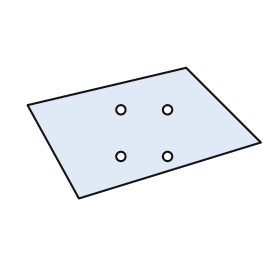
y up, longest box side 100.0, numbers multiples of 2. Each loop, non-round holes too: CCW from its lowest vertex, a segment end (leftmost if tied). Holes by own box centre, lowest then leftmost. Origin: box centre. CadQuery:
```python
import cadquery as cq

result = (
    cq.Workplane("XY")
    .moveTo(-28.0, -28.0)
    .lineTo(50.0, -4.0)
    .lineTo(18.0, 28.0)
    .lineTo(-50.0, 12.0)
    .close()
    .moveTo(-10.0, -10.0)
    .circle(2.0)
    .moveTo(10.0, -10.0)
    .circle(2.0)
    .moveTo(-10.0, 10.0)
    .circle(2.0)
    .moveTo(10.0, 10.0)
    .circle(2.0)
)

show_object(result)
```